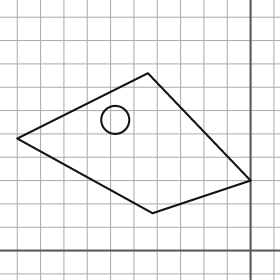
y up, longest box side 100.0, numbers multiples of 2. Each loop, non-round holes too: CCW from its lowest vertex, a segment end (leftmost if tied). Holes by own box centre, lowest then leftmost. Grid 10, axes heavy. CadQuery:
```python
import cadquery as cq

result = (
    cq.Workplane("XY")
    .moveTo(-42.0, 16.0)
    .lineTo(0.0, 30.0)
    .lineTo(-44.0, 76.0)
    .lineTo(-100.0, 48.0)
    .close()
    .moveTo(-58.0, 56.0)
    .circle(6.0)
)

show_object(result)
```